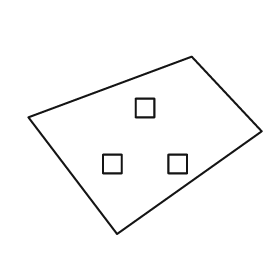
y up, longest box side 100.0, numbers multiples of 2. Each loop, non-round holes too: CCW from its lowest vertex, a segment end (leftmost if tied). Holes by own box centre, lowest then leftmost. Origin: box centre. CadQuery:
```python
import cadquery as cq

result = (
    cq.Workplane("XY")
    .moveTo(-12.0, -38.0)
    .lineTo(50.0, 6.0)
    .lineTo(20.0, 38.0)
    .lineTo(-50.0, 12.0)
    .close()
    .moveTo(-18.0, -12.0)
    .lineTo(-10.0, -12.0)
    .lineTo(-10.0, -4.0)
    .lineTo(-18.0, -4.0)
    .close()
    .moveTo(10.0, -12.0)
    .lineTo(18.0, -12.0)
    .lineTo(18.0, -4.0)
    .lineTo(10.0, -4.0)
    .close()
    .moveTo(-4.0, 12.0)
    .lineTo(4.0, 12.0)
    .lineTo(4.0, 20.0)
    .lineTo(-4.0, 20.0)
    .close()
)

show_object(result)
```